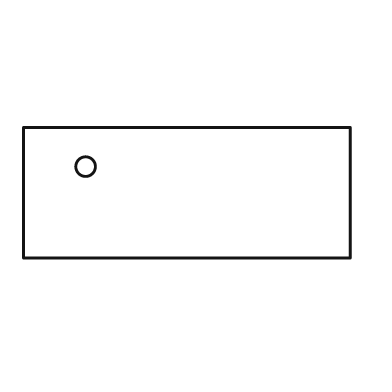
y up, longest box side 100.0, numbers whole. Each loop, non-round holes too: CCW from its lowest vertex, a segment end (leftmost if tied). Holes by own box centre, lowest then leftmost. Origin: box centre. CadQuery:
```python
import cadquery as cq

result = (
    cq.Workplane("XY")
    .moveTo(-50.0, -20.0)
    .lineTo(50.0, -20.0)
    .lineTo(50.0, 20.0)
    .lineTo(-50.0, 20.0)
    .close()
    .moveTo(-31.0, 8.0)
    .circle(3.0)
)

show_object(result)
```